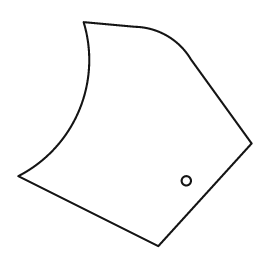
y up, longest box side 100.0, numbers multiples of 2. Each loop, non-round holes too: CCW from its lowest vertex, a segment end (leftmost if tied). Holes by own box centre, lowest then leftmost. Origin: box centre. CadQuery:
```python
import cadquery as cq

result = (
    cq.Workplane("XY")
    .moveTo(10.0, -48.0)
    .lineTo(50.0, -4.0)
    .lineTo(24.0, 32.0)
    .threePointArc((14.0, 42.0), (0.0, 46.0))
    .lineTo(-22.0, 48.0)
    .threePointArc((-24.0, 10.0), (-50.0, -18.0))
    .close()
    .moveTo(22.0, -20.0)
    .circle(2.0)
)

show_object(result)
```